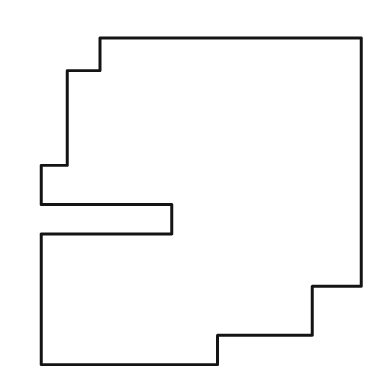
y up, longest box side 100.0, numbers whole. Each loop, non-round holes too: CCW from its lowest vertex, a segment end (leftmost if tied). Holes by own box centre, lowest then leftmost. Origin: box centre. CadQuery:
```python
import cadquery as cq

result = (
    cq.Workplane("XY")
    .moveTo(-49.0, -50.0)
    .lineTo(5.0, -50.0)
    .lineTo(5.0, -41.0)
    .lineTo(34.0, -41.0)
    .lineTo(34.0, -26.0)
    .lineTo(49.0, -26.0)
    .lineTo(49.0, 50.0)
    .lineTo(-31.0, 50.0)
    .lineTo(-31.0, 40.0)
    .lineTo(-41.0, 40.0)
    .lineTo(-41.0, 11.0)
    .lineTo(-49.0, 11.0)
    .lineTo(-49.0, -1.0)
    .lineTo(-9.0, -1.0)
    .lineTo(-9.0, -10.0)
    .lineTo(-49.0, -10.0)
    .close()
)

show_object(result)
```